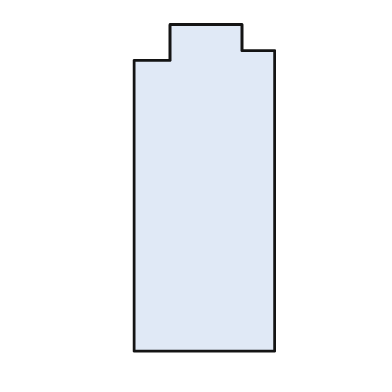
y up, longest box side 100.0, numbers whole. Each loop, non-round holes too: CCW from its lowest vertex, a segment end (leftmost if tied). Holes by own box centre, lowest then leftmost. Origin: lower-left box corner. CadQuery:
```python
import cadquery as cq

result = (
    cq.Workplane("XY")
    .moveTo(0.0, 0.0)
    .lineTo(43.0, 0.0)
    .lineTo(43.0, 92.0)
    .lineTo(33.0, 92.0)
    .lineTo(33.0, 100.0)
    .lineTo(11.0, 100.0)
    .lineTo(11.0, 89.0)
    .lineTo(0.0, 89.0)
    .close()
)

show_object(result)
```